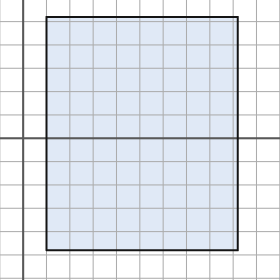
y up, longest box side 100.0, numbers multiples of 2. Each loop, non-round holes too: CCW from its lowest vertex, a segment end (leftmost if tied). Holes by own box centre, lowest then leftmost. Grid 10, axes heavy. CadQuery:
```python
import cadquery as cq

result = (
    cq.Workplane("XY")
    .moveTo(10.0, -48.0)
    .lineTo(92.0, -48.0)
    .lineTo(92.0, 52.0)
    .lineTo(10.0, 52.0)
    .close()
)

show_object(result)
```